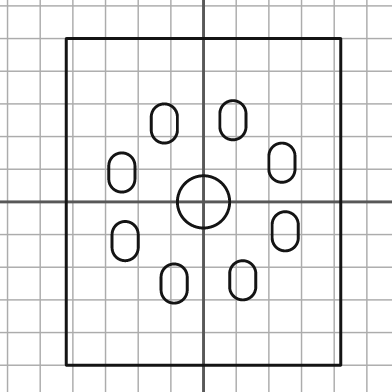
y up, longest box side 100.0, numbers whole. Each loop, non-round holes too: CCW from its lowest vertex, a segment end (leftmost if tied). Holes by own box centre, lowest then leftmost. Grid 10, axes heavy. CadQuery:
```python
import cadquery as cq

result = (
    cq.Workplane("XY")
    .moveTo(-42.0, -50.0)
    .lineTo(42.0, -50.0)
    .lineTo(42.0, 50.0)
    .lineTo(-42.0, 50.0)
    .close()
    .moveTo(-13.0, -27.0)
    .threePointArc((-9.0, -31.0), (-5.0, -27.0))
    .lineTo(-5.0, -23.0)
    .threePointArc((-9.0, -19.0), (-13.0, -23.0))
    .close()
    .moveTo(8.0, -26.0)
    .threePointArc((12.0, -30.0), (16.0, -26.0))
    .lineTo(16.0, -22.0)
    .threePointArc((12.0, -18.0), (8.0, -22.0))
    .close()
    .moveTo(-28.0, -14.0)
    .threePointArc((-24.0, -18.0), (-20.0, -14.0))
    .lineTo(-20.0, -10.0)
    .threePointArc((-24.0, -6.0), (-28.0, -10.0))
    .close()
    .moveTo(21.0, -11.0)
    .threePointArc((25.0, -15.0), (29.0, -11.0))
    .lineTo(29.0, -7.0)
    .threePointArc((25.0, -3.0), (21.0, -7.0))
    .close()
    .moveTo(0.0, 0.0)
    .circle(8.0)
    .moveTo(-29.0, 7.0)
    .threePointArc((-25.0, 3.0), (-21.0, 7.0))
    .lineTo(-21.0, 11.0)
    .threePointArc((-25.0, 15.0), (-29.0, 11.0))
    .close()
    .moveTo(20.0, 10.0)
    .threePointArc((24.0, 6.0), (28.0, 10.0))
    .lineTo(28.0, 14.0)
    .threePointArc((24.0, 18.0), (20.0, 14.0))
    .close()
    .moveTo(-16.0, 22.0)
    .threePointArc((-12.0, 18.0), (-8.0, 22.0))
    .lineTo(-8.0, 26.0)
    .threePointArc((-12.0, 30.0), (-16.0, 26.0))
    .close()
    .moveTo(5.0, 23.0)
    .threePointArc((9.0, 19.0), (13.0, 23.0))
    .lineTo(13.0, 27.0)
    .threePointArc((9.0, 31.0), (5.0, 27.0))
    .close()
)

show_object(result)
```